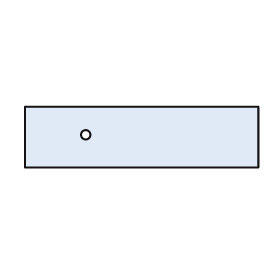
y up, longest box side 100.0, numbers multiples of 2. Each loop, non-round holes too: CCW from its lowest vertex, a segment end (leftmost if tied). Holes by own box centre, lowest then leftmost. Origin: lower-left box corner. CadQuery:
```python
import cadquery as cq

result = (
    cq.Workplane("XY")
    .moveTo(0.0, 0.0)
    .lineTo(100.0, 0.0)
    .lineTo(100.0, 26.0)
    .lineTo(0.0, 26.0)
    .close()
    .moveTo(26.0, 14.0)
    .circle(2.0)
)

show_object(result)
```